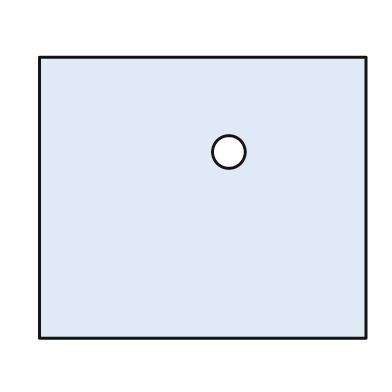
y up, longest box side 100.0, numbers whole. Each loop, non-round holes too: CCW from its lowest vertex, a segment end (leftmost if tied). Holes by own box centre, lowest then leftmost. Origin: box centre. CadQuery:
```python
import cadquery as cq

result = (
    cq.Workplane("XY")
    .moveTo(-50.0, -43.0)
    .lineTo(50.0, -43.0)
    .lineTo(50.0, 43.0)
    .lineTo(-50.0, 43.0)
    .close()
    .moveTo(8.0, 14.0)
    .circle(5.0)
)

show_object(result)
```